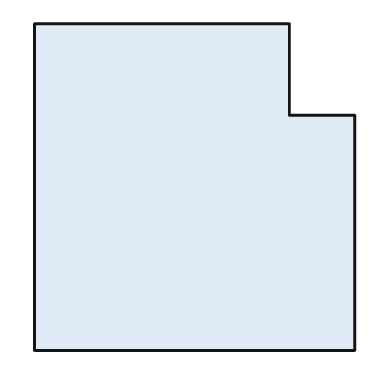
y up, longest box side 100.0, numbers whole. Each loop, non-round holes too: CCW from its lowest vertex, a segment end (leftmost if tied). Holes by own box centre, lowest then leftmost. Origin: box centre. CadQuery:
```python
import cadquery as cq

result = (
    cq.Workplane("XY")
    .moveTo(-49.0, -50.0)
    .lineTo(49.0, -50.0)
    .lineTo(49.0, 22.0)
    .lineTo(29.0, 22.0)
    .lineTo(29.0, 50.0)
    .lineTo(-49.0, 50.0)
    .close()
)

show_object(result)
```